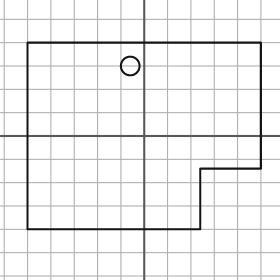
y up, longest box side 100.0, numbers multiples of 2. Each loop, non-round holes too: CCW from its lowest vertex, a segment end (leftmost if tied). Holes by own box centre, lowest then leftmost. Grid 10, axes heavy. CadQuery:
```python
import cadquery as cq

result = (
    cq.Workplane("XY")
    .moveTo(-50.0, -40.0)
    .lineTo(24.0, -40.0)
    .lineTo(24.0, -14.0)
    .lineTo(50.0, -14.0)
    .lineTo(50.0, 40.0)
    .lineTo(-50.0, 40.0)
    .close()
    .moveTo(-6.0, 30.0)
    .circle(4.0)
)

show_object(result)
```